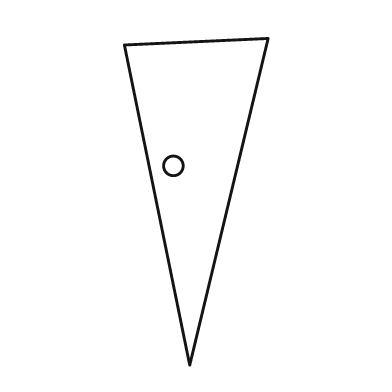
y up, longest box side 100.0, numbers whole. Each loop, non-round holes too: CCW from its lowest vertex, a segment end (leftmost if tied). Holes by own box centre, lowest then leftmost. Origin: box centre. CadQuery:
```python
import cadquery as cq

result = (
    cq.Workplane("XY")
    .moveTo(-2.0, -50.0)
    .lineTo(22.0, 50.0)
    .lineTo(-22.0, 48.0)
    .close()
    .moveTo(-7.0, 11.0)
    .circle(3.0)
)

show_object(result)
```